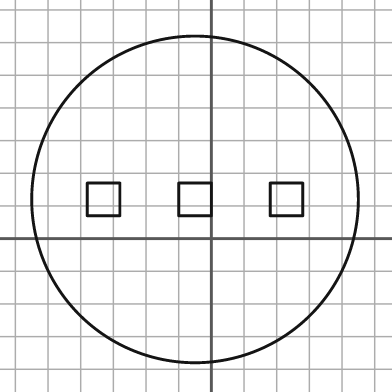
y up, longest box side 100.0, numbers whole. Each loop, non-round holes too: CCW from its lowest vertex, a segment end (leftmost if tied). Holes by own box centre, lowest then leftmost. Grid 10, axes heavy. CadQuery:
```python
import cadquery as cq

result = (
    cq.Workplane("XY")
    .moveTo(-5.0, 12.0)
    .circle(50.0)
    .moveTo(-38.0, 7.0)
    .lineTo(-28.0, 7.0)
    .lineTo(-28.0, 17.0)
    .lineTo(-38.0, 17.0)
    .close()
    .moveTo(-10.0, 7.0)
    .lineTo(0.0, 7.0)
    .lineTo(0.0, 17.0)
    .lineTo(-10.0, 17.0)
    .close()
    .moveTo(18.0, 7.0)
    .lineTo(28.0, 7.0)
    .lineTo(28.0, 17.0)
    .lineTo(18.0, 17.0)
    .close()
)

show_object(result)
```